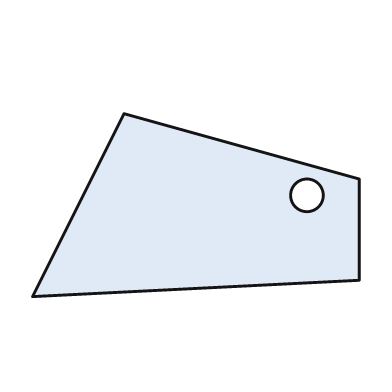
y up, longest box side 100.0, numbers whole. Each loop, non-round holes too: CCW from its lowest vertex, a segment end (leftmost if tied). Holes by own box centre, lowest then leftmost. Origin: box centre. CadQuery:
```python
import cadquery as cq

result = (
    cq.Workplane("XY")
    .moveTo(-50.0, -28.0)
    .lineTo(50.0, -23.0)
    .lineTo(50.0, 8.0)
    .lineTo(-22.0, 28.0)
    .close()
    .moveTo(34.0, 3.0)
    .circle(5.0)
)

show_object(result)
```